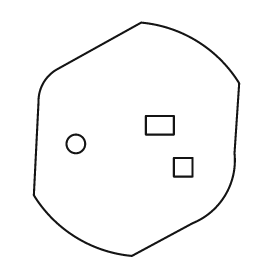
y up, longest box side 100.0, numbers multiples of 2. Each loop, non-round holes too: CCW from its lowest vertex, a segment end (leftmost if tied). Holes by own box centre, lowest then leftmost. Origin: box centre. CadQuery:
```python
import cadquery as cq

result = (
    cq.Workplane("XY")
    .moveTo(-2.0, -50.0)
    .lineTo(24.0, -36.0)
    .threePointArc((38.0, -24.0), (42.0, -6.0))
    .lineTo(44.0, 24.0)
    .threePointArc((26.0, 42.0), (2.0, 50.0))
    .lineTo(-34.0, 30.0)
    .threePointArc((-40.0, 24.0), (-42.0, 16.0))
    .lineTo(-44.0, -24.0)
    .threePointArc((-26.0, -42.0), (-2.0, -50.0))
    .close()
    .moveTo(16.0, -16.0)
    .lineTo(24.0, -16.0)
    .lineTo(24.0, -8.0)
    .lineTo(16.0, -8.0)
    .close()
    .moveTo(-26.0, -2.0)
    .circle(4.0)
    .moveTo(4.0, 2.0)
    .lineTo(16.0, 2.0)
    .lineTo(16.0, 10.0)
    .lineTo(4.0, 10.0)
    .close()
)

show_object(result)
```